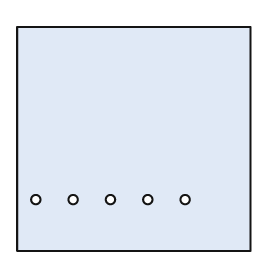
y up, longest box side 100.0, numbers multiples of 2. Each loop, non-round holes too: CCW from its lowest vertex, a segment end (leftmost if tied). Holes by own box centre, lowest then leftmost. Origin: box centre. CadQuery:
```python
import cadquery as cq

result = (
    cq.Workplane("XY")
    .moveTo(-50.0, -48.0)
    .lineTo(50.0, -48.0)
    .lineTo(50.0, 48.0)
    .lineTo(-50.0, 48.0)
    .close()
    .moveTo(-42.0, -26.0)
    .circle(2.0)
    .moveTo(-26.0, -26.0)
    .circle(2.0)
    .moveTo(-10.0, -26.0)
    .circle(2.0)
    .moveTo(6.0, -26.0)
    .circle(2.0)
    .moveTo(22.0, -26.0)
    .circle(2.0)
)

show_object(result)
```